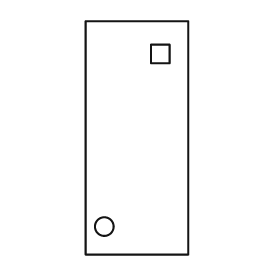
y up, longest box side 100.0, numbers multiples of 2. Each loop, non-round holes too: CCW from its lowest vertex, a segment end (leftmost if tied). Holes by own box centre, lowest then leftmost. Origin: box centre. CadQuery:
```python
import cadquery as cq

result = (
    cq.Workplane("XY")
    .moveTo(-22.0, -50.0)
    .lineTo(22.0, -50.0)
    .lineTo(22.0, 50.0)
    .lineTo(-22.0, 50.0)
    .close()
    .moveTo(-14.0, -38.0)
    .circle(4.0)
    .moveTo(6.0, 32.0)
    .lineTo(14.0, 32.0)
    .lineTo(14.0, 40.0)
    .lineTo(6.0, 40.0)
    .close()
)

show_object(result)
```